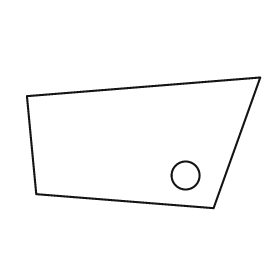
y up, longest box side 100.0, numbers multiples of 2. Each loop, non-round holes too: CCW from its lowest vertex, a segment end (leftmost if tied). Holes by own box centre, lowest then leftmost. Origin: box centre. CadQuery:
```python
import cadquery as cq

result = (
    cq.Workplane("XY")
    .moveTo(30.0, -28.0)
    .lineTo(50.0, 28.0)
    .lineTo(-50.0, 20.0)
    .lineTo(-46.0, -22.0)
    .close()
    .moveTo(18.0, -14.0)
    .circle(6.0)
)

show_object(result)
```